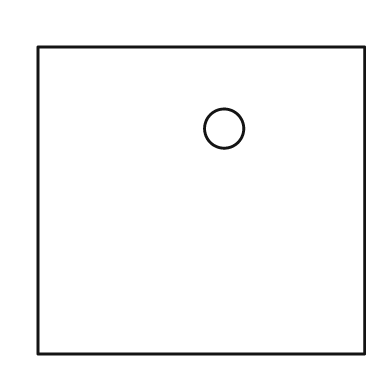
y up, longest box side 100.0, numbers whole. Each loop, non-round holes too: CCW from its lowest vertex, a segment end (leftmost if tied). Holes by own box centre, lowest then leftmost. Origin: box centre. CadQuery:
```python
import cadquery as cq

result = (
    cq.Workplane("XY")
    .moveTo(-50.0, -47.0)
    .lineTo(50.0, -47.0)
    .lineTo(50.0, 47.0)
    .lineTo(-50.0, 47.0)
    .close()
    .moveTo(7.0, 22.0)
    .circle(6.0)
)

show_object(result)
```